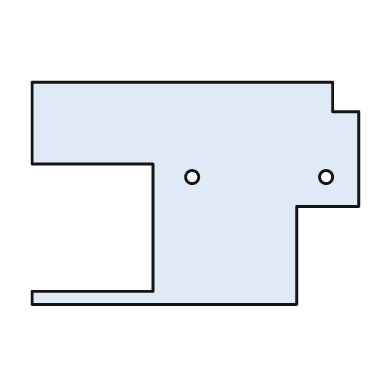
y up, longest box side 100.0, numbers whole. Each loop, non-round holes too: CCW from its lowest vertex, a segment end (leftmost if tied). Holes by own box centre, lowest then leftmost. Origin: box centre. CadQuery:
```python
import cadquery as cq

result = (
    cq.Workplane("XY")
    .moveTo(-50.0, -34.0)
    .lineTo(31.0, -34.0)
    .lineTo(31.0, -4.0)
    .lineTo(50.0, -4.0)
    .lineTo(50.0, 25.0)
    .lineTo(42.0, 25.0)
    .lineTo(42.0, 34.0)
    .lineTo(-50.0, 34.0)
    .lineTo(-50.0, 9.0)
    .lineTo(-13.0, 9.0)
    .lineTo(-13.0, -30.0)
    .lineTo(-50.0, -30.0)
    .close()
    .moveTo(-1.0, 5.0)
    .circle(2.0)
    .moveTo(40.0, 5.0)
    .circle(2.0)
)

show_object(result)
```